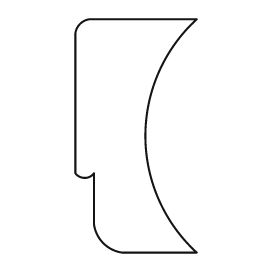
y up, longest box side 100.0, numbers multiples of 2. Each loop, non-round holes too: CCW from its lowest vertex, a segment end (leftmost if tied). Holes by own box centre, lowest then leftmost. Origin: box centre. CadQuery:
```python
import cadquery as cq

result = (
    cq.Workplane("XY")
    .moveTo(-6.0, -50.0)
    .lineTo(26.0, -50.0)
    .threePointArc((4.0, 0.0), (26.0, 50.0))
    .lineTo(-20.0, 50.0)
    .threePointArc((-24.0, 48.0), (-26.0, 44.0))
    .lineTo(-26.0, -16.0)
    .threePointArc((-22.0, -18.0), (-18.0, -16.0))
    .lineTo(-18.0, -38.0)
    .threePointArc((-14.0, -46.0), (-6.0, -50.0))
    .close()
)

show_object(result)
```